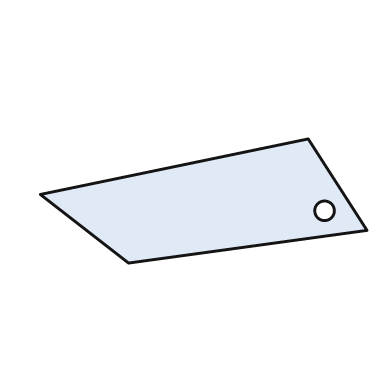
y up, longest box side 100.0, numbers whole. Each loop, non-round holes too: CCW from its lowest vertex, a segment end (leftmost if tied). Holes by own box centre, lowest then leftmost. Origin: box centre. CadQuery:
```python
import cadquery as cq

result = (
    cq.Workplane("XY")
    .moveTo(-23.0, -19.0)
    .lineTo(50.0, -9.0)
    .lineTo(32.0, 19.0)
    .lineTo(-50.0, 2.0)
    .close()
    .moveTo(37.0, -3.0)
    .circle(3.0)
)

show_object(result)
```